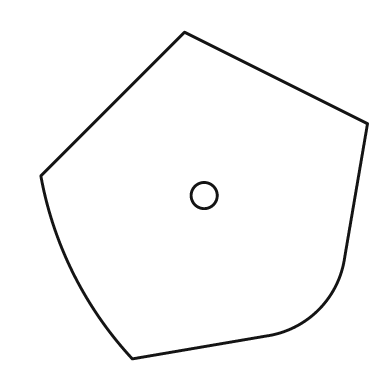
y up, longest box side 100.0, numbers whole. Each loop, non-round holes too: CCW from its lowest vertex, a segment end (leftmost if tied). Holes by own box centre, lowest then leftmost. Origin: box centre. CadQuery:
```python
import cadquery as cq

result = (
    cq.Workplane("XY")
    .moveTo(-22.0, -50.0)
    .lineTo(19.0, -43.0)
    .threePointArc((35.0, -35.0), (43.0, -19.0))
    .lineTo(50.0, 22.0)
    .lineTo(-6.0, 50.0)
    .lineTo(-50.0, 6.0)
    .threePointArc((-40.0, -24.0), (-22.0, -50.0))
    .close()
    .moveTo(0.0, 0.0)
    .circle(4.0)
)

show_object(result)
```